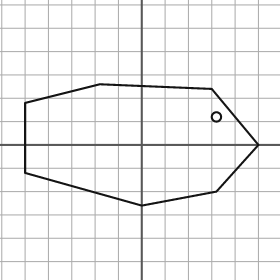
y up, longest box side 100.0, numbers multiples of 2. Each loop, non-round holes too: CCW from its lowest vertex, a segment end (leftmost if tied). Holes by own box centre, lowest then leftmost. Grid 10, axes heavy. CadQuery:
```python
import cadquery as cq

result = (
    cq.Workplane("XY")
    .moveTo(0.0, -26.0)
    .lineTo(32.0, -20.0)
    .lineTo(50.0, 0.0)
    .lineTo(30.0, 24.0)
    .lineTo(-18.0, 26.0)
    .lineTo(-50.0, 18.0)
    .lineTo(-50.0, -12.0)
    .close()
    .moveTo(32.0, 12.0)
    .circle(2.0)
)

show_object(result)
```